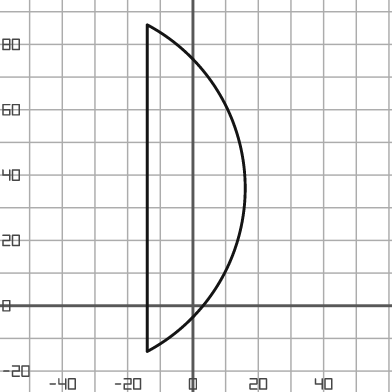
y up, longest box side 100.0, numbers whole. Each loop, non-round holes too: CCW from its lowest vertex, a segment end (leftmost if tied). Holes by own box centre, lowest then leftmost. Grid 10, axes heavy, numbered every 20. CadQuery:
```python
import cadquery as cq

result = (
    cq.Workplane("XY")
    .moveTo(-14.0, -14.0)
    .threePointArc((16.0, 36.0), (-14.0, 86.0))
    .close()
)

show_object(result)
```